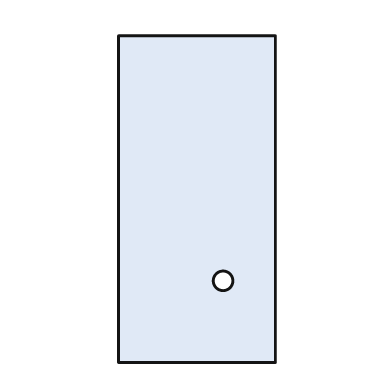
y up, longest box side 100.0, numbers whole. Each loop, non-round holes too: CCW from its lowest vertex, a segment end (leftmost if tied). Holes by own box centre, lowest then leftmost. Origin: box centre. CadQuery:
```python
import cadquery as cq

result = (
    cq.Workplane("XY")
    .moveTo(-24.0, -50.0)
    .lineTo(24.0, -50.0)
    .lineTo(24.0, 50.0)
    .lineTo(-24.0, 50.0)
    .close()
    .moveTo(8.0, -25.0)
    .circle(3.0)
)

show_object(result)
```